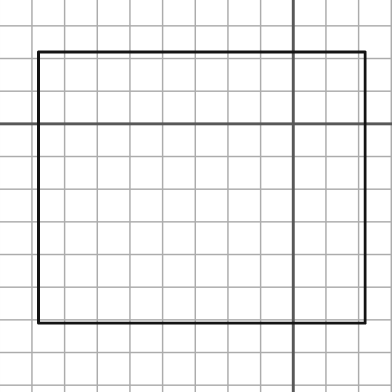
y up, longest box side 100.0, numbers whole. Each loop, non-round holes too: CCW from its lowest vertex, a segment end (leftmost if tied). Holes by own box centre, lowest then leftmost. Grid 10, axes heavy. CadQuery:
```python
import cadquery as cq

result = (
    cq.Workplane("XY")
    .moveTo(-78.0, -61.0)
    .lineTo(22.0, -61.0)
    .lineTo(22.0, 22.0)
    .lineTo(-78.0, 22.0)
    .close()
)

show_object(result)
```